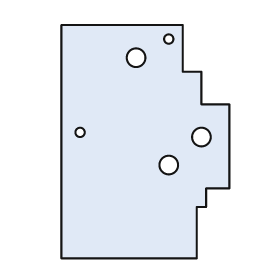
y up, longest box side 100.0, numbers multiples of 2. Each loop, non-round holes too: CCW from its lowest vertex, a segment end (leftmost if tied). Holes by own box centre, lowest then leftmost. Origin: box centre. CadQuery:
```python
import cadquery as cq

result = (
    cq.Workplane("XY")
    .moveTo(-36.0, -50.0)
    .lineTo(22.0, -50.0)
    .lineTo(22.0, -28.0)
    .lineTo(26.0, -28.0)
    .lineTo(26.0, -20.0)
    .lineTo(36.0, -20.0)
    .lineTo(36.0, 16.0)
    .lineTo(24.0, 16.0)
    .lineTo(24.0, 30.0)
    .lineTo(16.0, 30.0)
    .lineTo(16.0, 50.0)
    .lineTo(-36.0, 50.0)
    .close()
    .moveTo(10.0, -10.0)
    .circle(4.0)
    .moveTo(24.0, 2.0)
    .circle(4.0)
    .moveTo(-28.0, 4.0)
    .circle(2.0)
    .moveTo(-4.0, 36.0)
    .circle(4.0)
    .moveTo(10.0, 44.0)
    .circle(2.0)
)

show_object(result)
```